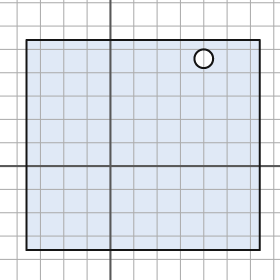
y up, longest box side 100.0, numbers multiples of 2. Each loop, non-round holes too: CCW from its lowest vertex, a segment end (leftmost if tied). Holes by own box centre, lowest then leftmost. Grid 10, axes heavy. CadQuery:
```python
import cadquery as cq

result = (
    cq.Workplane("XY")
    .moveTo(-36.0, -36.0)
    .lineTo(64.0, -36.0)
    .lineTo(64.0, 54.0)
    .lineTo(-36.0, 54.0)
    .close()
    .moveTo(40.0, 46.0)
    .circle(4.0)
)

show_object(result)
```